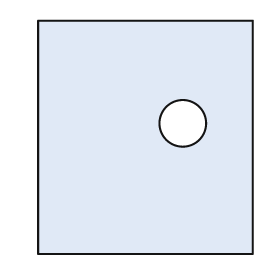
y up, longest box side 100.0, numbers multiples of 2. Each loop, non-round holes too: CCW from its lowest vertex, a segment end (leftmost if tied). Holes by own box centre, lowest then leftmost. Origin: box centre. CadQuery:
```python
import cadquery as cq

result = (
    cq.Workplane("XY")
    .moveTo(-46.0, -50.0)
    .lineTo(46.0, -50.0)
    .lineTo(46.0, 50.0)
    .lineTo(-46.0, 50.0)
    .close()
    .moveTo(16.0, 6.0)
    .circle(10.0)
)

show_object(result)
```